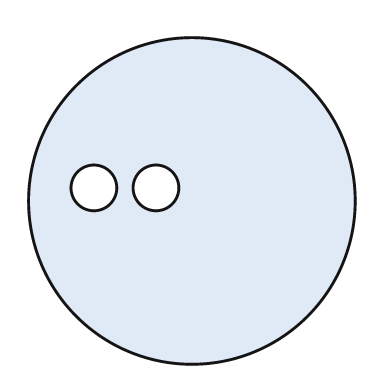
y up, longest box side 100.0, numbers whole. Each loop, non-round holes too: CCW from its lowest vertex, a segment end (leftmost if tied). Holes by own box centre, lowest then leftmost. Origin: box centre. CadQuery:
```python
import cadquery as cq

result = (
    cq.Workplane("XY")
    .moveTo(0.0, 0.0)
    .circle(50.0)
    .moveTo(-30.0, 4.0)
    .circle(7.0)
    .moveTo(-11.0, 4.0)
    .circle(7.0)
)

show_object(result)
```